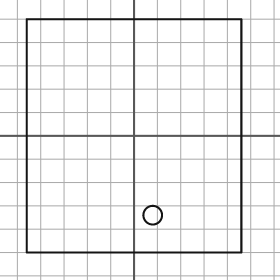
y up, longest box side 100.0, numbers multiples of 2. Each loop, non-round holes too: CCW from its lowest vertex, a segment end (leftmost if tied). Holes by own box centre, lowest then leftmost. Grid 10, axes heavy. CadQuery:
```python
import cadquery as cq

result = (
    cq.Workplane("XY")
    .moveTo(-46.0, -50.0)
    .lineTo(46.0, -50.0)
    .lineTo(46.0, 50.0)
    .lineTo(-46.0, 50.0)
    .close()
    .moveTo(8.0, -34.0)
    .circle(4.0)
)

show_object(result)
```